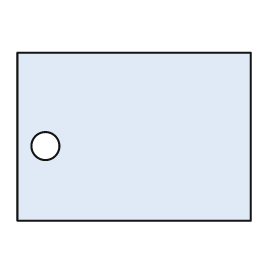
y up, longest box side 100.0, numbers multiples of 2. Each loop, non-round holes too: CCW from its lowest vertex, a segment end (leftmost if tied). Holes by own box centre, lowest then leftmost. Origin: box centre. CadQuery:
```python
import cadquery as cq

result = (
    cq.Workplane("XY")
    .moveTo(-50.0, -36.0)
    .lineTo(50.0, -36.0)
    .lineTo(50.0, 36.0)
    .lineTo(-50.0, 36.0)
    .close()
    .moveTo(-38.0, -4.0)
    .circle(6.0)
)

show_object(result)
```